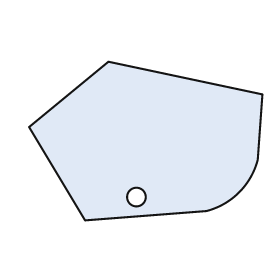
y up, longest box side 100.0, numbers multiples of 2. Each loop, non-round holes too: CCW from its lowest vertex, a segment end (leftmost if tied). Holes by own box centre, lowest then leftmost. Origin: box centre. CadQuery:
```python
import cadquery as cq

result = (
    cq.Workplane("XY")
    .moveTo(-26.0, -34.0)
    .lineTo(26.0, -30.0)
    .threePointArc((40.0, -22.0), (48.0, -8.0))
    .lineTo(50.0, 20.0)
    .lineTo(-16.0, 34.0)
    .lineTo(-50.0, 6.0)
    .close()
    .moveTo(-4.0, -24.0)
    .circle(4.0)
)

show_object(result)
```